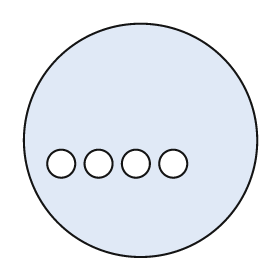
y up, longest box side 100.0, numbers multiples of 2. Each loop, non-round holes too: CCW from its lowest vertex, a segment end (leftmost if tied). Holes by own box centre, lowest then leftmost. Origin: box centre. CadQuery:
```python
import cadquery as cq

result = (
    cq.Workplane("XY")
    .moveTo(0.0, 0.0)
    .circle(50.0)
    .moveTo(-34.0, -10.0)
    .circle(6.0)
    .moveTo(-18.0, -10.0)
    .circle(6.0)
    .moveTo(-2.0, -10.0)
    .circle(6.0)
    .moveTo(14.0, -10.0)
    .circle(6.0)
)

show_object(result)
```